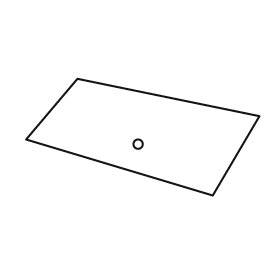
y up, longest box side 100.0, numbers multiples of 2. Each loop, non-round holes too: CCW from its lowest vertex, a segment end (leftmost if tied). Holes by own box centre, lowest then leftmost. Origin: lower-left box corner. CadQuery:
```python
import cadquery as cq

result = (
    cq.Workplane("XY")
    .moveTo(80.0, 0.0)
    .lineTo(100.0, 34.0)
    .lineTo(22.0, 50.0)
    .lineTo(0.0, 24.0)
    .close()
    .moveTo(48.0, 22.0)
    .circle(2.0)
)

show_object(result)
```